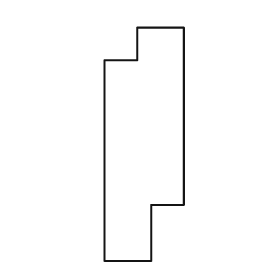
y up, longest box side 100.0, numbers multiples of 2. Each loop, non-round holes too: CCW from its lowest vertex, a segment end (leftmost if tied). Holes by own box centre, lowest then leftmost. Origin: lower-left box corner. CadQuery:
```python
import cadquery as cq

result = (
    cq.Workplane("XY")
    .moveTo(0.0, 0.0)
    .lineTo(20.0, 0.0)
    .lineTo(20.0, 24.0)
    .lineTo(34.0, 24.0)
    .lineTo(34.0, 100.0)
    .lineTo(14.0, 100.0)
    .lineTo(14.0, 86.0)
    .lineTo(0.0, 86.0)
    .close()
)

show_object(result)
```